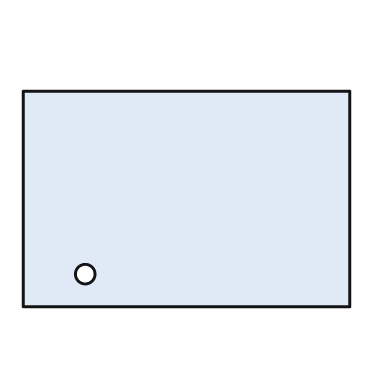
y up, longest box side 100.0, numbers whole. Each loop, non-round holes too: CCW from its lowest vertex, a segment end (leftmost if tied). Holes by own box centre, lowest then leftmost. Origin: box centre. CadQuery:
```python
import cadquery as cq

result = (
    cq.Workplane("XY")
    .moveTo(-50.0, -33.0)
    .lineTo(50.0, -33.0)
    .lineTo(50.0, 33.0)
    .lineTo(-50.0, 33.0)
    .close()
    .moveTo(-31.0, -23.0)
    .circle(3.0)
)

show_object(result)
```